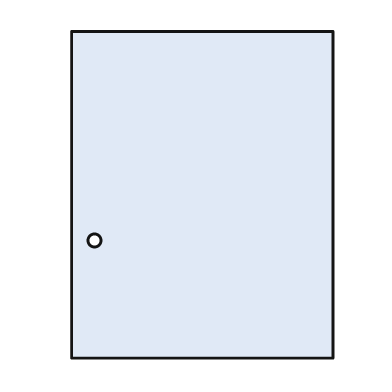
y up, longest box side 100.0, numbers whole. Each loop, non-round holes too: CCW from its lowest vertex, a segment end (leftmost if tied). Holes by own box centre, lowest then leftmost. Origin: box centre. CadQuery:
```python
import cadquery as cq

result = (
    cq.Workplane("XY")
    .moveTo(-40.0, -50.0)
    .lineTo(40.0, -50.0)
    .lineTo(40.0, 50.0)
    .lineTo(-40.0, 50.0)
    .close()
    .moveTo(-33.0, -14.0)
    .circle(2.0)
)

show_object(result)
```